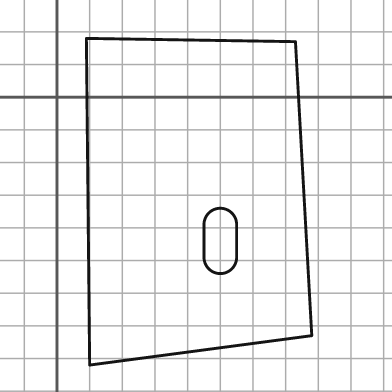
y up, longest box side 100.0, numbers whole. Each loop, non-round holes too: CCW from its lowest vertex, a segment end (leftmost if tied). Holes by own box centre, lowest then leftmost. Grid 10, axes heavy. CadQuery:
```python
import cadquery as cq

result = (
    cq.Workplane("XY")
    .moveTo(10.0, -82.0)
    .lineTo(78.0, -73.0)
    .lineTo(73.0, 17.0)
    .lineTo(9.0, 18.0)
    .close()
    .moveTo(45.0, -49.0)
    .threePointArc((50.0, -54.0), (55.0, -49.0))
    .lineTo(55.0, -39.0)
    .threePointArc((50.0, -34.0), (45.0, -39.0))
    .close()
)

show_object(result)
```